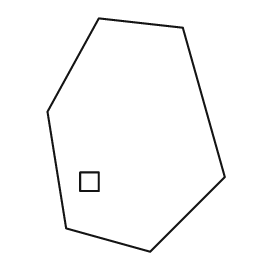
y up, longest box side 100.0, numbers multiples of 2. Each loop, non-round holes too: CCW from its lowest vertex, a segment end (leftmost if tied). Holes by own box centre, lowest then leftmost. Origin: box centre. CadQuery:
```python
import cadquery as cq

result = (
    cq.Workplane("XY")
    .moveTo(6.0, -50.0)
    .lineTo(38.0, -18.0)
    .lineTo(20.0, 46.0)
    .lineTo(-16.0, 50.0)
    .lineTo(-38.0, 10.0)
    .lineTo(-30.0, -40.0)
    .close()
    .moveTo(-24.0, -24.0)
    .lineTo(-16.0, -24.0)
    .lineTo(-16.0, -16.0)
    .lineTo(-24.0, -16.0)
    .close()
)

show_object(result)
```